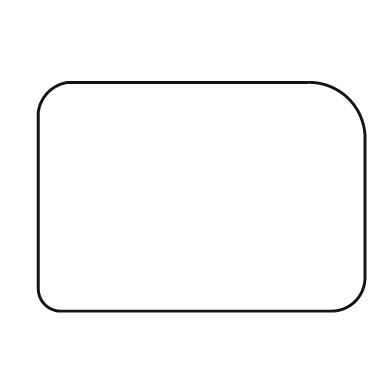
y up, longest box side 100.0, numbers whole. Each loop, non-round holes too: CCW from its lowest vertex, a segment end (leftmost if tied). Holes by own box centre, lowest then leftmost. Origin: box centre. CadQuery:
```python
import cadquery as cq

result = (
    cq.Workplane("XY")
    .moveTo(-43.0, -35.0)
    .lineTo(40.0, -35.0)
    .threePointArc((47.0, -32.0), (50.0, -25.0))
    .lineTo(50.0, 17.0)
    .threePointArc((45.0, 30.0), (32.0, 35.0))
    .lineTo(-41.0, 35.0)
    .threePointArc((-47.0, 32.0), (-50.0, 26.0))
    .lineTo(-50.0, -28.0)
    .threePointArc((-48.0, -33.0), (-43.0, -35.0))
    .close()
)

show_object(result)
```